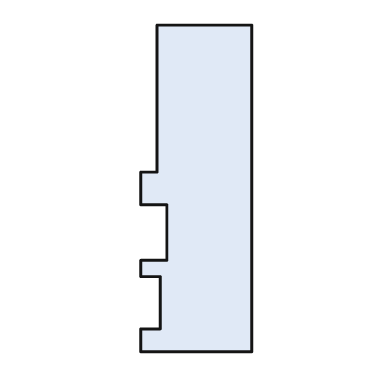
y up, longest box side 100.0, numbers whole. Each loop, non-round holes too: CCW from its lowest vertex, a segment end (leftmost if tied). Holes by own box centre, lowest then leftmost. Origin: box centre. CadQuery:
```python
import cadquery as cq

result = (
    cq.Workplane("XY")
    .moveTo(-17.0, -50.0)
    .lineTo(17.0, -50.0)
    .lineTo(17.0, 50.0)
    .lineTo(-12.0, 50.0)
    .lineTo(-12.0, 5.0)
    .lineTo(-17.0, 5.0)
    .lineTo(-17.0, -5.0)
    .lineTo(-9.0, -5.0)
    .lineTo(-9.0, -22.0)
    .lineTo(-17.0, -22.0)
    .lineTo(-17.0, -27.0)
    .lineTo(-11.0, -27.0)
    .lineTo(-11.0, -43.0)
    .lineTo(-17.0, -43.0)
    .close()
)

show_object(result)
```